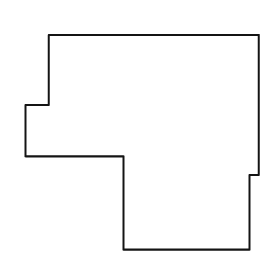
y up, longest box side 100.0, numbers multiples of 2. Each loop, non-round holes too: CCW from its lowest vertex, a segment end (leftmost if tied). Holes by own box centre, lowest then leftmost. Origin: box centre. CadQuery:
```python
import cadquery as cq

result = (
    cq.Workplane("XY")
    .moveTo(-8.0, -46.0)
    .lineTo(46.0, -46.0)
    .lineTo(46.0, -14.0)
    .lineTo(50.0, -14.0)
    .lineTo(50.0, 46.0)
    .lineTo(-40.0, 46.0)
    .lineTo(-40.0, 16.0)
    .lineTo(-50.0, 16.0)
    .lineTo(-50.0, -6.0)
    .lineTo(-8.0, -6.0)
    .close()
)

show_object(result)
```